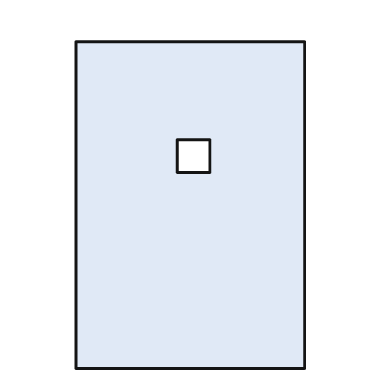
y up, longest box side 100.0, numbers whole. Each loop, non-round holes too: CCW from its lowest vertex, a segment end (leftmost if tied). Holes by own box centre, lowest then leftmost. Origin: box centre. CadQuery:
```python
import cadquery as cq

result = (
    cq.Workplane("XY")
    .moveTo(-35.0, -50.0)
    .lineTo(35.0, -50.0)
    .lineTo(35.0, 50.0)
    .lineTo(-35.0, 50.0)
    .close()
    .moveTo(-4.0, 10.0)
    .lineTo(6.0, 10.0)
    .lineTo(6.0, 20.0)
    .lineTo(-4.0, 20.0)
    .close()
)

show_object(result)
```